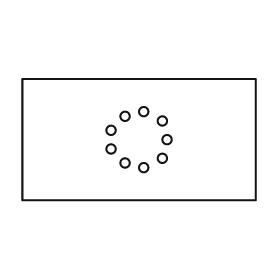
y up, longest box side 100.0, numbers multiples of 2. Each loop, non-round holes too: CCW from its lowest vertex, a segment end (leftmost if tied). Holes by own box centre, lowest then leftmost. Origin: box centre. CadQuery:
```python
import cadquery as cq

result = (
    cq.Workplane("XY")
    .moveTo(-50.0, -26.0)
    .lineTo(50.0, -26.0)
    .lineTo(50.0, 26.0)
    .lineTo(-50.0, 26.0)
    .close()
    .moveTo(2.0, -12.0)
    .circle(2.0)
    .moveTo(-6.0, -10.0)
    .circle(2.0)
    .moveTo(10.0, -8.0)
    .circle(2.0)
    .moveTo(-12.0, -4.0)
    .circle(2.0)
    .moveTo(12.0, 0.0)
    .circle(2.0)
    .moveTo(-12.0, 4.0)
    .circle(2.0)
    .moveTo(10.0, 8.0)
    .circle(2.0)
    .moveTo(-6.0, 10.0)
    .circle(2.0)
    .moveTo(2.0, 12.0)
    .circle(2.0)
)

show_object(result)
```